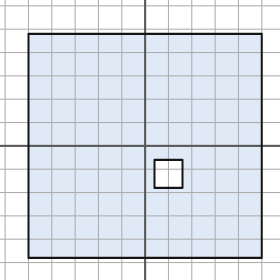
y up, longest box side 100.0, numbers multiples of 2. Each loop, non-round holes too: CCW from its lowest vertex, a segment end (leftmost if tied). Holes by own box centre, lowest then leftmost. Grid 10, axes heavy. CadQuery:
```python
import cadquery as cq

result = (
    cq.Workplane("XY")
    .moveTo(-50.0, -48.0)
    .lineTo(50.0, -48.0)
    .lineTo(50.0, 48.0)
    .lineTo(-50.0, 48.0)
    .close()
    .moveTo(4.0, -18.0)
    .lineTo(16.0, -18.0)
    .lineTo(16.0, -6.0)
    .lineTo(4.0, -6.0)
    .close()
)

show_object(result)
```